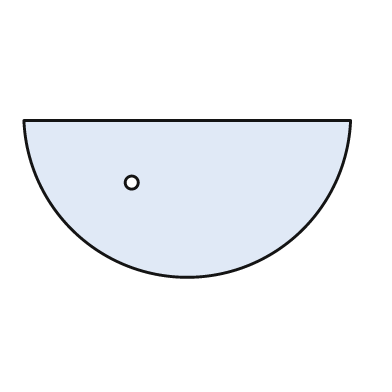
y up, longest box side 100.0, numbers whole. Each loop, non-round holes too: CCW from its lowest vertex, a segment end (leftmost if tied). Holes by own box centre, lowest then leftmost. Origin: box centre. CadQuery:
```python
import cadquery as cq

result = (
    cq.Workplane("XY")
    .moveTo(-50.0, 24.0)
    .threePointArc((0.0, -24.0), (50.0, 24.0))
    .close()
    .moveTo(-17.0, 5.0)
    .circle(2.0)
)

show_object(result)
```